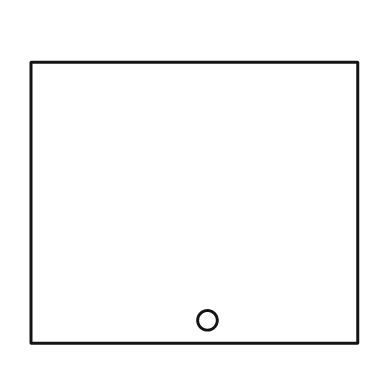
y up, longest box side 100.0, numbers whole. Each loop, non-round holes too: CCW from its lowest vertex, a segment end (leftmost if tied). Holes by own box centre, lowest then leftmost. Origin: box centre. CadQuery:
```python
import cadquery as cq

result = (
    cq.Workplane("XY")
    .moveTo(-50.0, -43.0)
    .lineTo(50.0, -43.0)
    .lineTo(50.0, 43.0)
    .lineTo(-50.0, 43.0)
    .close()
    .moveTo(4.0, -36.0)
    .circle(3.0)
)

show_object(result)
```